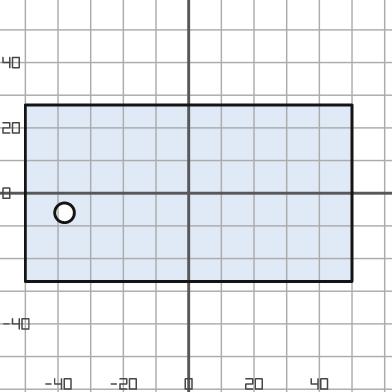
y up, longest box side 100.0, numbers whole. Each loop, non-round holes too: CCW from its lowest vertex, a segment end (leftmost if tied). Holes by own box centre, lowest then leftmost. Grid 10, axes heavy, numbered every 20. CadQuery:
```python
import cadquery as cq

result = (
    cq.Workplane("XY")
    .moveTo(-50.0, -27.0)
    .lineTo(50.0, -27.0)
    .lineTo(50.0, 27.0)
    .lineTo(-50.0, 27.0)
    .close()
    .moveTo(-38.0, -6.0)
    .circle(3.0)
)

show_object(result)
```